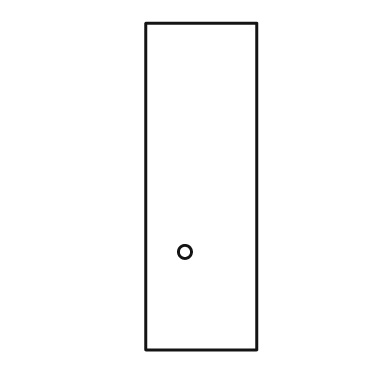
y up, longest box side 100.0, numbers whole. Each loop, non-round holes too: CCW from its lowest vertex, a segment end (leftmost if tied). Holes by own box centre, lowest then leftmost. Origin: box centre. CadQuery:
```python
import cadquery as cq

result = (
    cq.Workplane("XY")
    .moveTo(-17.0, -50.0)
    .lineTo(17.0, -50.0)
    .lineTo(17.0, 50.0)
    .lineTo(-17.0, 50.0)
    .close()
    .moveTo(-5.0, -20.0)
    .circle(2.0)
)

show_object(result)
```